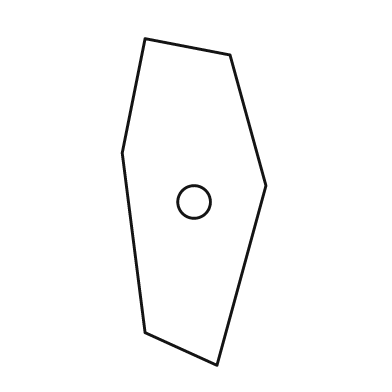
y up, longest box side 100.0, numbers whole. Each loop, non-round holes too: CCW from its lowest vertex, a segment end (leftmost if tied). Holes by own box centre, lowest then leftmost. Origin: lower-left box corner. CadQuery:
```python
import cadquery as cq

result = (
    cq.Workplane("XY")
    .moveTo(29.0, 0.0)
    .lineTo(44.0, 55.0)
    .lineTo(33.0, 95.0)
    .lineTo(7.0, 100.0)
    .lineTo(0.0, 65.0)
    .lineTo(7.0, 10.0)
    .close()
    .moveTo(22.0, 50.0)
    .circle(5.0)
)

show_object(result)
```